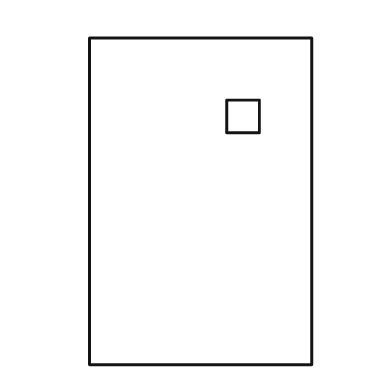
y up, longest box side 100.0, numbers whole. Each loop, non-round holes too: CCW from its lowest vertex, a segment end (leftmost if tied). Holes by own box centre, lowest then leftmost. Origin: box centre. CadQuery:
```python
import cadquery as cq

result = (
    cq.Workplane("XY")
    .moveTo(-34.0, -50.0)
    .lineTo(34.0, -50.0)
    .lineTo(34.0, 50.0)
    .lineTo(-34.0, 50.0)
    .close()
    .moveTo(8.0, 21.0)
    .lineTo(18.0, 21.0)
    .lineTo(18.0, 31.0)
    .lineTo(8.0, 31.0)
    .close()
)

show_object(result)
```